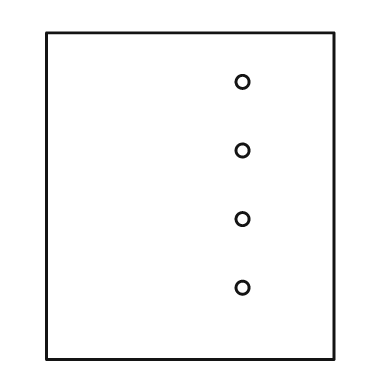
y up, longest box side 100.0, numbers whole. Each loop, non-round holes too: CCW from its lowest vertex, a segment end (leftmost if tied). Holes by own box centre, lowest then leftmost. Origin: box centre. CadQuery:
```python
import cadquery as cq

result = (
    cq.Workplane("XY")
    .moveTo(-44.0, -50.0)
    .lineTo(44.0, -50.0)
    .lineTo(44.0, 50.0)
    .lineTo(-44.0, 50.0)
    .close()
    .moveTo(16.0, -28.0)
    .circle(2.0)
    .moveTo(16.0, -7.0)
    .circle(2.0)
    .moveTo(16.0, 14.0)
    .circle(2.0)
    .moveTo(16.0, 35.0)
    .circle(2.0)
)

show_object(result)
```